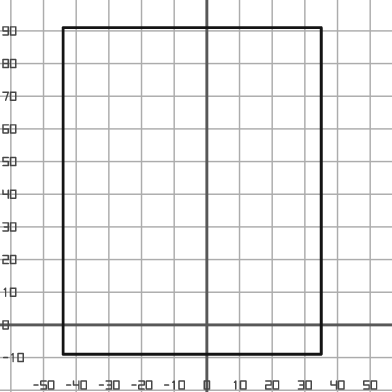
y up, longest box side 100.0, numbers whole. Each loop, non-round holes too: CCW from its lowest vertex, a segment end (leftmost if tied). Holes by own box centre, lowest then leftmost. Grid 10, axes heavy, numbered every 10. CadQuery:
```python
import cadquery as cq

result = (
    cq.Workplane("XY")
    .moveTo(-44.0, -9.0)
    .lineTo(35.0, -9.0)
    .lineTo(35.0, 91.0)
    .lineTo(-44.0, 91.0)
    .close()
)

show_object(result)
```